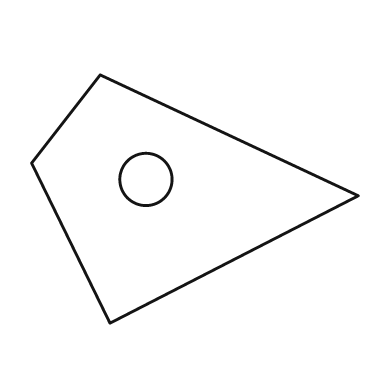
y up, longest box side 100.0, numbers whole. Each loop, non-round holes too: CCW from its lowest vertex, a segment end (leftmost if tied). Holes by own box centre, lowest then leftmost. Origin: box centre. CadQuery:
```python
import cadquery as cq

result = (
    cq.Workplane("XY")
    .moveTo(-26.0, -38.0)
    .lineTo(50.0, 1.0)
    .lineTo(-29.0, 38.0)
    .lineTo(-50.0, 11.0)
    .close()
    .moveTo(-15.0, 6.0)
    .circle(8.0)
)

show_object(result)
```